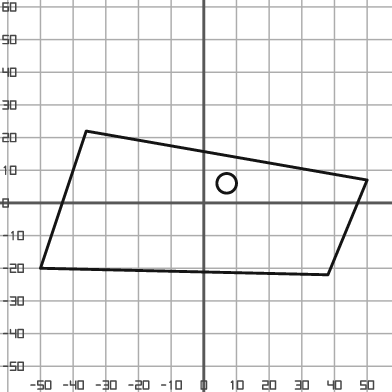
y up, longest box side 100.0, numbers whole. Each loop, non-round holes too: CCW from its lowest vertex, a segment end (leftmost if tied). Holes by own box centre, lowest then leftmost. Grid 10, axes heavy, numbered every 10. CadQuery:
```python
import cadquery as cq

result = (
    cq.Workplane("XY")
    .moveTo(38.0, -22.0)
    .lineTo(50.0, 7.0)
    .lineTo(-36.0, 22.0)
    .lineTo(-50.0, -20.0)
    .close()
    .moveTo(7.0, 6.0)
    .circle(3.0)
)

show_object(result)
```